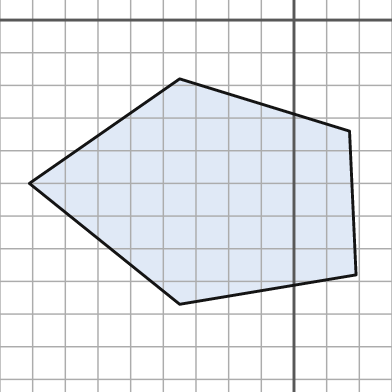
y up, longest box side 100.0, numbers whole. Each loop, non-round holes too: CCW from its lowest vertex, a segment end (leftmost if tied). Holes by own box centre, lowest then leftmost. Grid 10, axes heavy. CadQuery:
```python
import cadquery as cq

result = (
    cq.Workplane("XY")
    .moveTo(-35.0, -87.0)
    .lineTo(19.0, -78.0)
    .lineTo(17.0, -34.0)
    .lineTo(-35.0, -18.0)
    .lineTo(-81.0, -50.0)
    .close()
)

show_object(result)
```